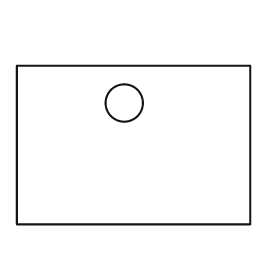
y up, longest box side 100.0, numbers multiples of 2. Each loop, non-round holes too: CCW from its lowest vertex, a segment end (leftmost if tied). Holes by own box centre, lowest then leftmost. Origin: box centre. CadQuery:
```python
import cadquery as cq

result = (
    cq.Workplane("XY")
    .moveTo(-50.0, -34.0)
    .lineTo(50.0, -34.0)
    .lineTo(50.0, 34.0)
    .lineTo(-50.0, 34.0)
    .close()
    .moveTo(-4.0, 18.0)
    .circle(8.0)
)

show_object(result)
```